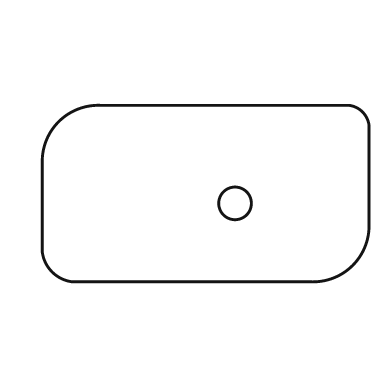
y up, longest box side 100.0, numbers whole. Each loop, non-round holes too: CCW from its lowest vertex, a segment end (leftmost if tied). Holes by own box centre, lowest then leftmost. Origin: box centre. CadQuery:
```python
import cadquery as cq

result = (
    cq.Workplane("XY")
    .moveTo(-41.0, -27.0)
    .lineTo(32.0, -27.0)
    .threePointArc((45.0, -22.0), (50.0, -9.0))
    .lineTo(50.0, 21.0)
    .threePointArc((48.0, 25.0), (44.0, 27.0))
    .lineTo(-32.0, 27.0)
    .threePointArc((-45.0, 22.0), (-50.0, 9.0))
    .lineTo(-50.0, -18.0)
    .threePointArc((-47.0, -24.0), (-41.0, -27.0))
    .close()
    .moveTo(9.0, -3.0)
    .circle(5.0)
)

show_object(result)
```